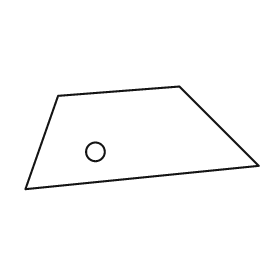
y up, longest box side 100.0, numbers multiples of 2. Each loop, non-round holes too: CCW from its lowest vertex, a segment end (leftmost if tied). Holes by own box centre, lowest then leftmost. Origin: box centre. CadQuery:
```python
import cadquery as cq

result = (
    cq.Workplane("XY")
    .moveTo(-50.0, -22.0)
    .lineTo(50.0, -12.0)
    .lineTo(16.0, 22.0)
    .lineTo(-36.0, 18.0)
    .close()
    .moveTo(-20.0, -6.0)
    .circle(4.0)
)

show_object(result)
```